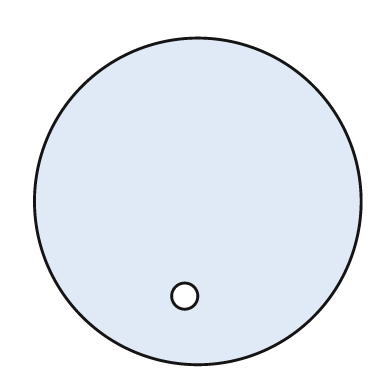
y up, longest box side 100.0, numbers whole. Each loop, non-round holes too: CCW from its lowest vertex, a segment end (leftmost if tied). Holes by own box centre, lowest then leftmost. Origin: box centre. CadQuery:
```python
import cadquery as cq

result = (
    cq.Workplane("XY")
    .moveTo(0.0, 0.0)
    .circle(50.0)
    .moveTo(-4.0, -29.0)
    .circle(4.0)
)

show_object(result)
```